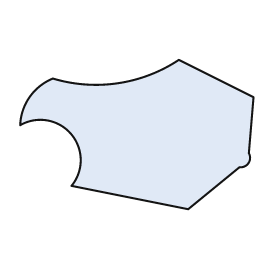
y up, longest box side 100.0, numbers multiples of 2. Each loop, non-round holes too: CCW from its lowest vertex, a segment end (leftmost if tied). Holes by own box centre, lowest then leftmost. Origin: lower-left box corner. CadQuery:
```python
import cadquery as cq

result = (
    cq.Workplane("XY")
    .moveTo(72.0, 0.0)
    .lineTo(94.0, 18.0)
    .threePointArc((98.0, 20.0), (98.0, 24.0))
    .lineTo(100.0, 48.0)
    .lineTo(68.0, 64.0)
    .threePointArc((42.0, 54.0), (14.0, 56.0))
    .threePointArc((4.0, 48.0), (0.0, 36.0))
    .threePointArc((22.0, 32.0), (22.0, 10.0))
    .close()
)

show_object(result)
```